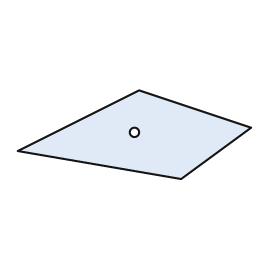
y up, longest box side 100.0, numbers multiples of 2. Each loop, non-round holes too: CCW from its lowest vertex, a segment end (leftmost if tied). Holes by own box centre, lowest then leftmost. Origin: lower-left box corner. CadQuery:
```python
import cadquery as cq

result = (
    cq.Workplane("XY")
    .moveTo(70.0, 0.0)
    .lineTo(100.0, 22.0)
    .lineTo(52.0, 38.0)
    .lineTo(0.0, 12.0)
    .close()
    .moveTo(50.0, 20.0)
    .circle(2.0)
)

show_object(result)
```